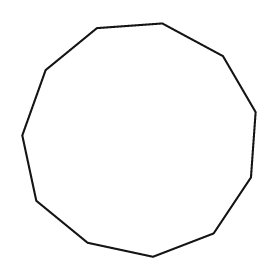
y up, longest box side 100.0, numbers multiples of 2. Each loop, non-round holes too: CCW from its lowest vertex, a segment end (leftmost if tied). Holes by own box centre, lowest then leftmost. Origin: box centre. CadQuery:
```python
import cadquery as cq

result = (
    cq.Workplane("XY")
    .moveTo(6.0, -50.0)
    .lineTo(32.0, -40.0)
    .lineTo(48.0, -16.0)
    .lineTo(50.0, 12.0)
    .lineTo(36.0, 36.0)
    .lineTo(10.0, 50.0)
    .lineTo(-18.0, 48.0)
    .lineTo(-40.0, 30.0)
    .lineTo(-50.0, 2.0)
    .lineTo(-44.0, -26.0)
    .lineTo(-22.0, -44.0)
    .close()
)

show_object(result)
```